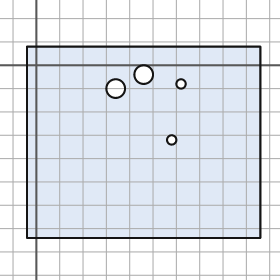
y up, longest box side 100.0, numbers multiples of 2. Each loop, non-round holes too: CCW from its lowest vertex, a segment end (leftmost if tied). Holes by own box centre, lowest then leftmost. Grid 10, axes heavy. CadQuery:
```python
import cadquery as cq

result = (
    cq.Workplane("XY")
    .moveTo(-4.0, -74.0)
    .lineTo(96.0, -74.0)
    .lineTo(96.0, 8.0)
    .lineTo(-4.0, 8.0)
    .close()
    .moveTo(58.0, -32.0)
    .circle(2.0)
    .moveTo(34.0, -10.0)
    .circle(4.0)
    .moveTo(62.0, -8.0)
    .circle(2.0)
    .moveTo(46.0, -4.0)
    .circle(4.0)
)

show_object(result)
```